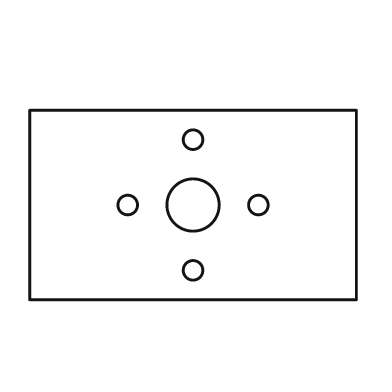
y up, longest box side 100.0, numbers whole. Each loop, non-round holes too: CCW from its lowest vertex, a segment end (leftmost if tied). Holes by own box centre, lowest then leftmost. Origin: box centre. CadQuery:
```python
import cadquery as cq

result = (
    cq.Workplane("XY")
    .moveTo(-50.0, -29.0)
    .lineTo(50.0, -29.0)
    .lineTo(50.0, 29.0)
    .lineTo(-50.0, 29.0)
    .close()
    .moveTo(0.0, -20.0)
    .circle(3.0)
    .moveTo(-20.0, 0.0)
    .circle(3.0)
    .moveTo(0.0, 0.0)
    .circle(8.0)
    .moveTo(20.0, 0.0)
    .circle(3.0)
    .moveTo(0.0, 20.0)
    .circle(3.0)
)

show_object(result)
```